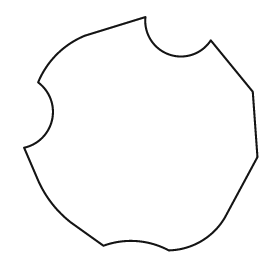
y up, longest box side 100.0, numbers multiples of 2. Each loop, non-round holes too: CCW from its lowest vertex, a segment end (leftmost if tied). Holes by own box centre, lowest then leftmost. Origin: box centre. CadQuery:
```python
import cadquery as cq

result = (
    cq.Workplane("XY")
    .moveTo(12.0, -50.0)
    .threePointArc((26.0, -46.0), (36.0, -36.0))
    .lineTo(50.0, -10.0)
    .lineTo(48.0, 18.0)
    .lineTo(30.0, 40.0)
    .threePointArc((12.0, 34.0), (2.0, 50.0))
    .lineTo(-24.0, 42.0)
    .threePointArc((-36.0, 34.0), (-44.0, 22.0))
    .threePointArc((-38.0, 6.0), (-50.0, -6.0))
    .lineTo(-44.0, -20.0)
    .threePointArc((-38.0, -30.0), (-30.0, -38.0))
    .lineTo(-16.0, -48.0)
    .threePointArc((-2.0, -46.0), (12.0, -50.0))
    .close()
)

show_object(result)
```